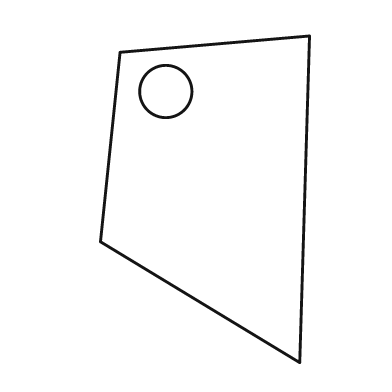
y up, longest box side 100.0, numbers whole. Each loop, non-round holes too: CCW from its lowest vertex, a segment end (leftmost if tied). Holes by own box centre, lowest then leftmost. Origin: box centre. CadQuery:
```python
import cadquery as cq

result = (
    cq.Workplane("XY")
    .moveTo(29.0, -50.0)
    .lineTo(32.0, 50.0)
    .lineTo(-26.0, 45.0)
    .lineTo(-32.0, -13.0)
    .close()
    .moveTo(-12.0, 33.0)
    .circle(8.0)
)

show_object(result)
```